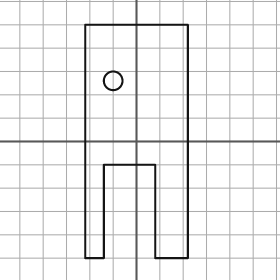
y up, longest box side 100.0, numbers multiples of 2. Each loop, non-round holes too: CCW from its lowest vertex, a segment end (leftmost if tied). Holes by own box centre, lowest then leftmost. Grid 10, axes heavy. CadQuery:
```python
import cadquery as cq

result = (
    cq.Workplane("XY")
    .moveTo(-22.0, -50.0)
    .lineTo(-14.0, -50.0)
    .lineTo(-14.0, -10.0)
    .lineTo(8.0, -10.0)
    .lineTo(8.0, -50.0)
    .lineTo(22.0, -50.0)
    .lineTo(22.0, 50.0)
    .lineTo(-22.0, 50.0)
    .close()
    .moveTo(-10.0, 26.0)
    .circle(4.0)
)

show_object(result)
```